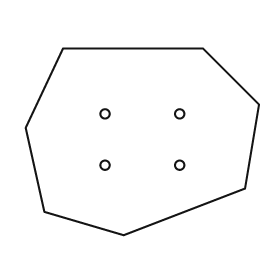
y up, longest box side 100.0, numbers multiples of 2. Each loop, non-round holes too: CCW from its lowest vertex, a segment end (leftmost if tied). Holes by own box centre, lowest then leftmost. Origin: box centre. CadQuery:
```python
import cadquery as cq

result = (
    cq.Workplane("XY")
    .moveTo(-8.0, -40.0)
    .lineTo(44.0, -20.0)
    .lineTo(50.0, 16.0)
    .lineTo(26.0, 40.0)
    .lineTo(-34.0, 40.0)
    .lineTo(-50.0, 6.0)
    .lineTo(-42.0, -30.0)
    .close()
    .moveTo(-16.0, -10.0)
    .circle(2.0)
    .moveTo(16.0, -10.0)
    .circle(2.0)
    .moveTo(-16.0, 12.0)
    .circle(2.0)
    .moveTo(16.0, 12.0)
    .circle(2.0)
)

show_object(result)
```